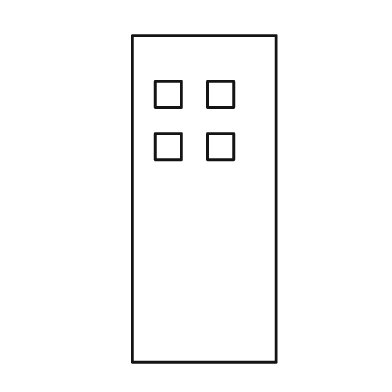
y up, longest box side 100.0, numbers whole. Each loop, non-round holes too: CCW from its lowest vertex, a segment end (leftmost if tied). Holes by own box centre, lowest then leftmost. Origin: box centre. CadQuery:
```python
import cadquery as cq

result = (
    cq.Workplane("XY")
    .moveTo(-22.0, -50.0)
    .lineTo(22.0, -50.0)
    .lineTo(22.0, 50.0)
    .lineTo(-22.0, 50.0)
    .close()
    .moveTo(-15.0, 12.0)
    .lineTo(-7.0, 12.0)
    .lineTo(-7.0, 20.0)
    .lineTo(-15.0, 20.0)
    .close()
    .moveTo(1.0, 12.0)
    .lineTo(9.0, 12.0)
    .lineTo(9.0, 20.0)
    .lineTo(1.0, 20.0)
    .close()
    .moveTo(-15.0, 28.0)
    .lineTo(-7.0, 28.0)
    .lineTo(-7.0, 36.0)
    .lineTo(-15.0, 36.0)
    .close()
    .moveTo(1.0, 28.0)
    .lineTo(9.0, 28.0)
    .lineTo(9.0, 36.0)
    .lineTo(1.0, 36.0)
    .close()
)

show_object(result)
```